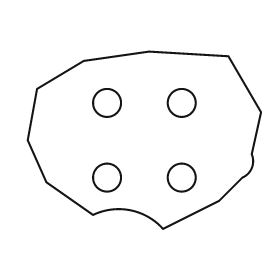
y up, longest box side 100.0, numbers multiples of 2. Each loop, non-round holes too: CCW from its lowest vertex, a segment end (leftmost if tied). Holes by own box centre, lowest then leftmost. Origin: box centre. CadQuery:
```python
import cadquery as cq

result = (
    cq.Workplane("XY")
    .moveTo(8.0, -38.0)
    .lineTo(32.0, -26.0)
    .lineTo(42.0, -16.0)
    .threePointArc((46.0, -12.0), (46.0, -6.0))
    .lineTo(50.0, 12.0)
    .lineTo(36.0, 36.0)
    .lineTo(2.0, 38.0)
    .lineTo(-26.0, 34.0)
    .lineTo(-46.0, 22.0)
    .lineTo(-50.0, 0.0)
    .lineTo(-42.0, -18.0)
    .lineTo(-22.0, -32.0)
    .threePointArc((-6.0, -30.0), (8.0, -38.0))
    .close()
    .moveTo(-16.0, -16.0)
    .circle(6.0)
    .moveTo(16.0, -16.0)
    .circle(6.0)
    .moveTo(-16.0, 16.0)
    .circle(6.0)
    .moveTo(16.0, 16.0)
    .circle(6.0)
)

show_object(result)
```